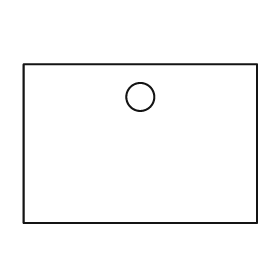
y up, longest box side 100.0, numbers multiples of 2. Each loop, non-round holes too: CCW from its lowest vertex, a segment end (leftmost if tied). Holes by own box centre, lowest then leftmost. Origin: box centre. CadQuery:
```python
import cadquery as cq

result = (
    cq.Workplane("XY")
    .moveTo(-50.0, -34.0)
    .lineTo(50.0, -34.0)
    .lineTo(50.0, 34.0)
    .lineTo(-50.0, 34.0)
    .close()
    .moveTo(0.0, 20.0)
    .circle(6.0)
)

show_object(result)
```